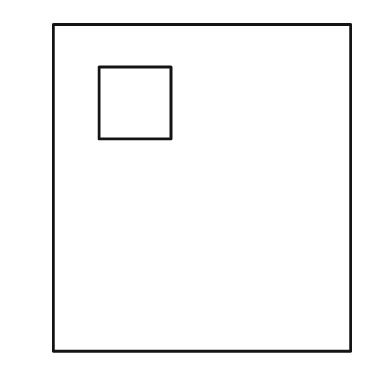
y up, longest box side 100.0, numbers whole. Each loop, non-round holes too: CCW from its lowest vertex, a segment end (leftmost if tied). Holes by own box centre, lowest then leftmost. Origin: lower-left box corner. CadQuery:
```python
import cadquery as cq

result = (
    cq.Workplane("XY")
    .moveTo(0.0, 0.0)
    .lineTo(91.0, 0.0)
    .lineTo(91.0, 100.0)
    .lineTo(0.0, 100.0)
    .close()
    .moveTo(14.0, 65.0)
    .lineTo(36.0, 65.0)
    .lineTo(36.0, 87.0)
    .lineTo(14.0, 87.0)
    .close()
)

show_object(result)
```